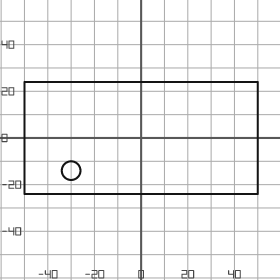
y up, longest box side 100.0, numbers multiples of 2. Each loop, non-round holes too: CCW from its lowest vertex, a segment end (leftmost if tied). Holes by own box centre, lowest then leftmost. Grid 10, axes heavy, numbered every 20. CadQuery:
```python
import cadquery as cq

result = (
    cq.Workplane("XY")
    .moveTo(-50.0, -24.0)
    .lineTo(50.0, -24.0)
    .lineTo(50.0, 24.0)
    .lineTo(-50.0, 24.0)
    .close()
    .moveTo(-30.0, -14.0)
    .circle(4.0)
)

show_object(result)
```